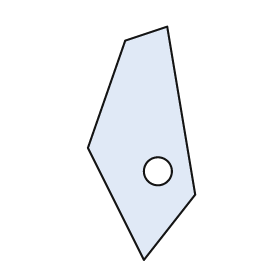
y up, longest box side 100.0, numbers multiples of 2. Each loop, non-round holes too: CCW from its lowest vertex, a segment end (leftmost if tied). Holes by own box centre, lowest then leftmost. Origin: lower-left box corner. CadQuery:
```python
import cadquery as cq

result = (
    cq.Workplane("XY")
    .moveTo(24.0, 0.0)
    .lineTo(46.0, 28.0)
    .lineTo(34.0, 100.0)
    .lineTo(16.0, 94.0)
    .lineTo(0.0, 48.0)
    .close()
    .moveTo(30.0, 38.0)
    .circle(6.0)
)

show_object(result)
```